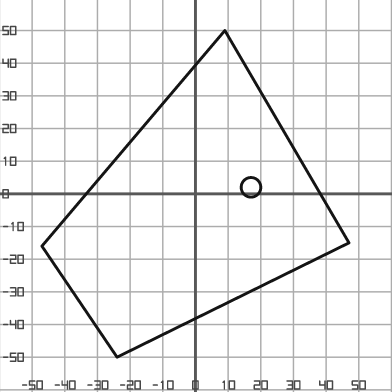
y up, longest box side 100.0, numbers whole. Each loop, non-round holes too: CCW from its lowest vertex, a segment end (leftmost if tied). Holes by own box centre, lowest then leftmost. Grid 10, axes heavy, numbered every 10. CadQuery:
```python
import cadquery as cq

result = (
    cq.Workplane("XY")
    .moveTo(-24.0, -50.0)
    .lineTo(47.0, -15.0)
    .lineTo(9.0, 50.0)
    .lineTo(-47.0, -16.0)
    .close()
    .moveTo(17.0, 2.0)
    .circle(3.0)
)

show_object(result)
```